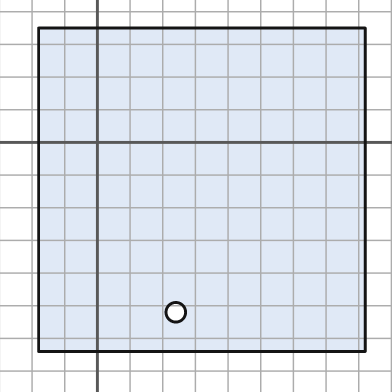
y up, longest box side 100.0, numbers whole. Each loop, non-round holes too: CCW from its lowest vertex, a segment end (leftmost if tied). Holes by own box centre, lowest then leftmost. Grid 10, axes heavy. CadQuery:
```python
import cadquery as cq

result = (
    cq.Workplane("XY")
    .moveTo(-18.0, -64.0)
    .lineTo(82.0, -64.0)
    .lineTo(82.0, 35.0)
    .lineTo(-18.0, 35.0)
    .close()
    .moveTo(24.0, -52.0)
    .circle(3.0)
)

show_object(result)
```